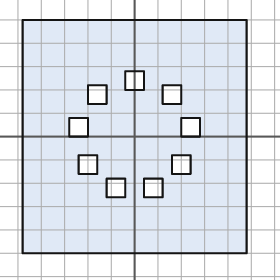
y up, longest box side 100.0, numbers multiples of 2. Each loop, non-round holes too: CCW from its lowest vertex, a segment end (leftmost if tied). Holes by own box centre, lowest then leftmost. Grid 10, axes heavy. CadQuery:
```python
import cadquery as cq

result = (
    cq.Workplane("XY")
    .moveTo(-48.0, -50.0)
    .lineTo(48.0, -50.0)
    .lineTo(48.0, 50.0)
    .lineTo(-48.0, 50.0)
    .close()
    .moveTo(-12.0, -26.0)
    .lineTo(-4.0, -26.0)
    .lineTo(-4.0, -18.0)
    .lineTo(-12.0, -18.0)
    .close()
    .moveTo(4.0, -26.0)
    .lineTo(12.0, -26.0)
    .lineTo(12.0, -18.0)
    .lineTo(4.0, -18.0)
    .close()
    .moveTo(-24.0, -16.0)
    .lineTo(-16.0, -16.0)
    .lineTo(-16.0, -8.0)
    .lineTo(-24.0, -8.0)
    .close()
    .moveTo(16.0, -16.0)
    .lineTo(24.0, -16.0)
    .lineTo(24.0, -8.0)
    .lineTo(16.0, -8.0)
    .close()
    .moveTo(-28.0, 0.0)
    .lineTo(-20.0, 0.0)
    .lineTo(-20.0, 8.0)
    .lineTo(-28.0, 8.0)
    .close()
    .moveTo(20.0, 0.0)
    .lineTo(28.0, 0.0)
    .lineTo(28.0, 8.0)
    .lineTo(20.0, 8.0)
    .close()
    .moveTo(-20.0, 14.0)
    .lineTo(-12.0, 14.0)
    .lineTo(-12.0, 22.0)
    .lineTo(-20.0, 22.0)
    .close()
    .moveTo(12.0, 14.0)
    .lineTo(20.0, 14.0)
    .lineTo(20.0, 22.0)
    .lineTo(12.0, 22.0)
    .close()
    .moveTo(-4.0, 20.0)
    .lineTo(4.0, 20.0)
    .lineTo(4.0, 28.0)
    .lineTo(-4.0, 28.0)
    .close()
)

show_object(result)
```